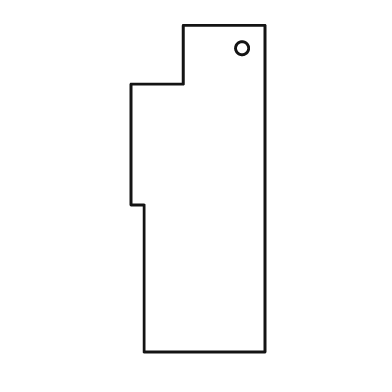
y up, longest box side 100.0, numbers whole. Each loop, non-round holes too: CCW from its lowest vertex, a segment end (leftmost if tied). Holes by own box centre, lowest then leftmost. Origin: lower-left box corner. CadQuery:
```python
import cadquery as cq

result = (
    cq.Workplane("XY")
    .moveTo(4.0, 0.0)
    .lineTo(41.0, 0.0)
    .lineTo(41.0, 100.0)
    .lineTo(16.0, 100.0)
    .lineTo(16.0, 82.0)
    .lineTo(0.0, 82.0)
    .lineTo(0.0, 45.0)
    .lineTo(4.0, 45.0)
    .close()
    .moveTo(34.0, 93.0)
    .circle(2.0)
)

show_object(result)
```